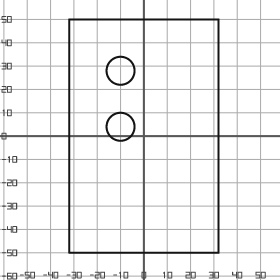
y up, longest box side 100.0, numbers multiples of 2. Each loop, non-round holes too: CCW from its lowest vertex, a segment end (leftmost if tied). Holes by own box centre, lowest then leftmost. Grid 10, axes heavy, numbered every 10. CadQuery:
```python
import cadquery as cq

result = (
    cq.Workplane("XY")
    .moveTo(-32.0, -50.0)
    .lineTo(32.0, -50.0)
    .lineTo(32.0, 50.0)
    .lineTo(-32.0, 50.0)
    .close()
    .moveTo(-10.0, 4.0)
    .circle(6.0)
    .moveTo(-10.0, 28.0)
    .circle(6.0)
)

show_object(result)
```